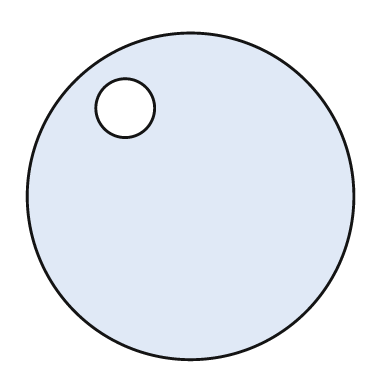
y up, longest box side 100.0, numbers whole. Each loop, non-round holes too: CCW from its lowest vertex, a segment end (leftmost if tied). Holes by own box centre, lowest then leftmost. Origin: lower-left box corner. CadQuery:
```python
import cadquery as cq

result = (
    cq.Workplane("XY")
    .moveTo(50.0, 50.0)
    .circle(50.0)
    .moveTo(30.0, 77.0)
    .circle(9.0)
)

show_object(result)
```